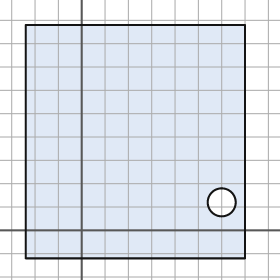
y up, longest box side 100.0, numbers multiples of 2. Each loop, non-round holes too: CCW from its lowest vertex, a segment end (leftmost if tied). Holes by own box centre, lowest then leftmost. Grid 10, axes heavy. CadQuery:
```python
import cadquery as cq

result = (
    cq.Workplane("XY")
    .moveTo(-24.0, -12.0)
    .lineTo(70.0, -12.0)
    .lineTo(70.0, 88.0)
    .lineTo(-24.0, 88.0)
    .close()
    .moveTo(60.0, 12.0)
    .circle(6.0)
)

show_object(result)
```